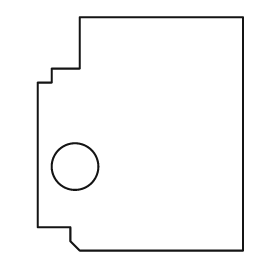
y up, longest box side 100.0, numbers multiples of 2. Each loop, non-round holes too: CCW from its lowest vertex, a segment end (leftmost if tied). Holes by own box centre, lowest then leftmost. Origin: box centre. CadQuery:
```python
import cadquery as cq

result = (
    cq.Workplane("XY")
    .moveTo(-26.0, -50.0)
    .lineTo(44.0, -50.0)
    .lineTo(44.0, 50.0)
    .lineTo(-26.0, 50.0)
    .lineTo(-26.0, 28.0)
    .lineTo(-38.0, 28.0)
    .lineTo(-38.0, 22.0)
    .lineTo(-44.0, 22.0)
    .lineTo(-44.0, -40.0)
    .lineTo(-30.0, -40.0)
    .lineTo(-30.0, -46.0)
    .close()
    .moveTo(-28.0, -14.0)
    .circle(10.0)
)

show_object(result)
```